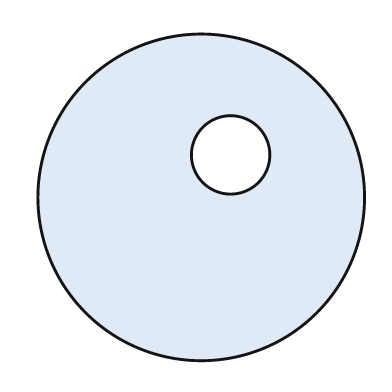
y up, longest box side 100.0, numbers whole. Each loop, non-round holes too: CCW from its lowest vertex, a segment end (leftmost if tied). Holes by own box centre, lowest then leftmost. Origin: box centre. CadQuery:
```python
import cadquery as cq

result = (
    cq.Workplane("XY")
    .moveTo(0.0, 0.0)
    .circle(50.0)
    .moveTo(9.0, 13.0)
    .circle(12.0)
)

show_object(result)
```